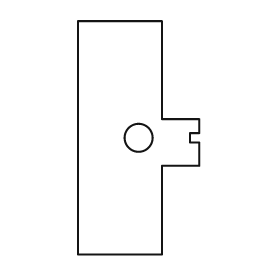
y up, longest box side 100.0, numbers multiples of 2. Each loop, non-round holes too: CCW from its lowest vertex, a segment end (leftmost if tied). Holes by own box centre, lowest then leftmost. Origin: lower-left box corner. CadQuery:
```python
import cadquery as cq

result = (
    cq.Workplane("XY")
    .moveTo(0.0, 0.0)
    .lineTo(36.0, 0.0)
    .lineTo(36.0, 38.0)
    .lineTo(52.0, 38.0)
    .lineTo(52.0, 48.0)
    .lineTo(48.0, 48.0)
    .lineTo(48.0, 52.0)
    .lineTo(52.0, 52.0)
    .lineTo(52.0, 58.0)
    .lineTo(36.0, 58.0)
    .lineTo(36.0, 100.0)
    .lineTo(0.0, 100.0)
    .close()
    .moveTo(26.0, 50.0)
    .circle(6.0)
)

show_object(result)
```